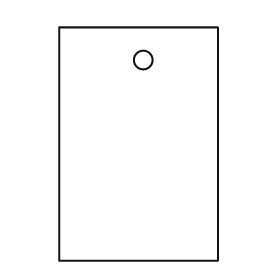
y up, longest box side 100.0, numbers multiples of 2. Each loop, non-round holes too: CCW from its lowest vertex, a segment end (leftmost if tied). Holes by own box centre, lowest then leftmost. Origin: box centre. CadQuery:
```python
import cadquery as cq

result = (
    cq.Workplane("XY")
    .moveTo(-34.0, -50.0)
    .lineTo(34.0, -50.0)
    .lineTo(34.0, 50.0)
    .lineTo(-34.0, 50.0)
    .close()
    .moveTo(2.0, 36.0)
    .circle(4.0)
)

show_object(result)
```